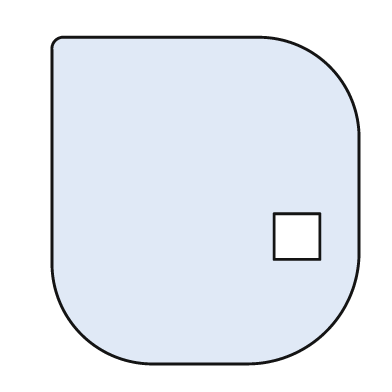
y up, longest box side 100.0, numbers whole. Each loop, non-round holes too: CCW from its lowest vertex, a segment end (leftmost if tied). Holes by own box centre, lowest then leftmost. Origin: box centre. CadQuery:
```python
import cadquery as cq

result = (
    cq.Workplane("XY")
    .moveTo(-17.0, -50.0)
    .lineTo(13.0, -50.0)
    .threePointArc((37.0, -40.0), (47.0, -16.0))
    .lineTo(47.0, 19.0)
    .threePointArc((38.0, 41.0), (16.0, 50.0))
    .lineTo(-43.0, 50.0)
    .threePointArc((-46.0, 49.0), (-47.0, 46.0))
    .lineTo(-47.0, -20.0)
    .threePointArc((-38.0, -41.0), (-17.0, -50.0))
    .close()
    .moveTo(21.0, -18.0)
    .lineTo(35.0, -18.0)
    .lineTo(35.0, -4.0)
    .lineTo(21.0, -4.0)
    .close()
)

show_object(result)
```